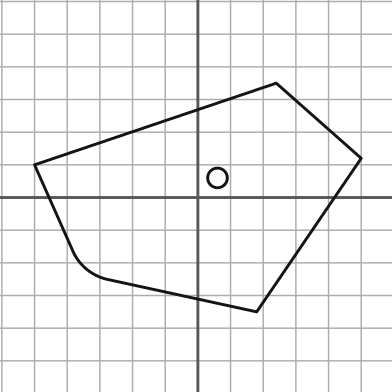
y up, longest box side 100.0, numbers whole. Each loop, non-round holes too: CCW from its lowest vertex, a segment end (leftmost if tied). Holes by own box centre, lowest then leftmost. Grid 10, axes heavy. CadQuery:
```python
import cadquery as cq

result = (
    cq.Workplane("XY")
    .moveTo(18.0, -35.0)
    .lineTo(50.0, 12.0)
    .lineTo(24.0, 35.0)
    .lineTo(-50.0, 10.0)
    .lineTo(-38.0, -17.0)
    .threePointArc((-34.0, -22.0), (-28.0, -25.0))
    .close()
    .moveTo(6.0, 6.0)
    .circle(3.0)
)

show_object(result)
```